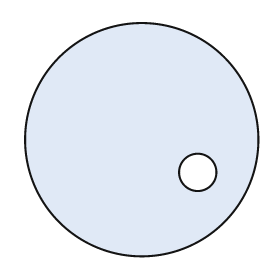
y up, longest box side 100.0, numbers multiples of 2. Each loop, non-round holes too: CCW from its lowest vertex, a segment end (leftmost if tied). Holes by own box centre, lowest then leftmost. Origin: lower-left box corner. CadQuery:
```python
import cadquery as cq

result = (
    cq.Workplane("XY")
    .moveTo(50.0, 50.0)
    .circle(50.0)
    .moveTo(74.0, 36.0)
    .circle(8.0)
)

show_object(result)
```